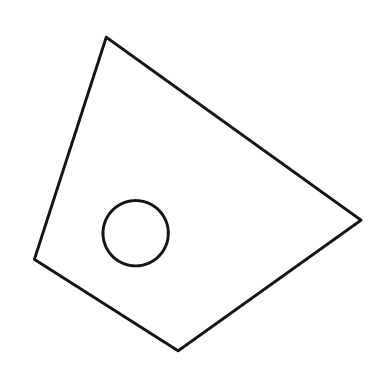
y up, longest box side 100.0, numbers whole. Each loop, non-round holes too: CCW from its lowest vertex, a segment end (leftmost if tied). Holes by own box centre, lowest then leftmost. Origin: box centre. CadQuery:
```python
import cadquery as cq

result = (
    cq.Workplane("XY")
    .moveTo(-6.0, -48.0)
    .lineTo(50.0, -8.0)
    .lineTo(-28.0, 48.0)
    .lineTo(-50.0, -20.0)
    .close()
    .moveTo(-19.0, -12.0)
    .circle(10.0)
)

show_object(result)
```